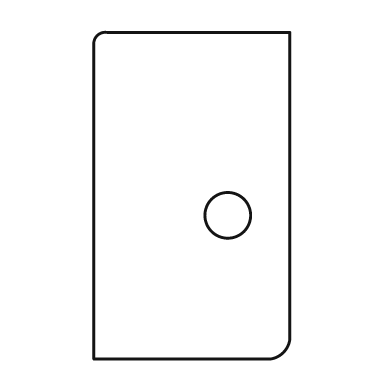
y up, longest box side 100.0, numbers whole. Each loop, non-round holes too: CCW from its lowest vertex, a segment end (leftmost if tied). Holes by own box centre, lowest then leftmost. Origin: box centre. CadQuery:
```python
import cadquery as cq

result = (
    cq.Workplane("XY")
    .moveTo(-30.0, -50.0)
    .lineTo(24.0, -50.0)
    .threePointArc((28.0, -48.0), (30.0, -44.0))
    .lineTo(30.0, 50.0)
    .lineTo(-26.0, 50.0)
    .threePointArc((-29.0, 49.0), (-30.0, 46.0))
    .close()
    .moveTo(11.0, -6.0)
    .circle(7.0)
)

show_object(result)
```